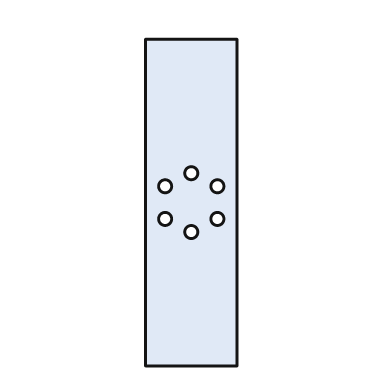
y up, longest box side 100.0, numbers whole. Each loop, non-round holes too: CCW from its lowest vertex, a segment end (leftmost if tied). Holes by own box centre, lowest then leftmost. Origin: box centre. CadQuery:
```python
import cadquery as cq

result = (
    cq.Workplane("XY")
    .moveTo(-14.0, -50.0)
    .lineTo(14.0, -50.0)
    .lineTo(14.0, 50.0)
    .lineTo(-14.0, 50.0)
    .close()
    .moveTo(0.0, -9.0)
    .circle(2.0)
    .moveTo(-8.0, -5.0)
    .circle(2.0)
    .moveTo(8.0, -5.0)
    .circle(2.0)
    .moveTo(-8.0, 5.0)
    .circle(2.0)
    .moveTo(8.0, 5.0)
    .circle(2.0)
    .moveTo(0.0, 9.0)
    .circle(2.0)
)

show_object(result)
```